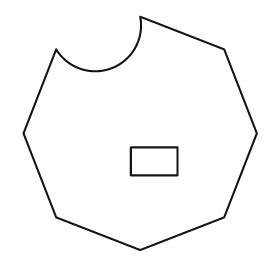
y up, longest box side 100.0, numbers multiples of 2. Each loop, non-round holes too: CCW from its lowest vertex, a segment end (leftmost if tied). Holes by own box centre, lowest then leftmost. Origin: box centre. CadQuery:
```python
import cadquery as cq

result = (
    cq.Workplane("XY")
    .moveTo(0.0, -50.0)
    .lineTo(36.0, -36.0)
    .lineTo(50.0, 0.0)
    .lineTo(36.0, 36.0)
    .lineTo(0.0, 50.0)
    .threePointArc((-12.0, 28.0), (-36.0, 36.0))
    .lineTo(-50.0, 0.0)
    .lineTo(-36.0, -36.0)
    .close()
    .moveTo(-4.0, -18.0)
    .lineTo(16.0, -18.0)
    .lineTo(16.0, -6.0)
    .lineTo(-4.0, -6.0)
    .close()
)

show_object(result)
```